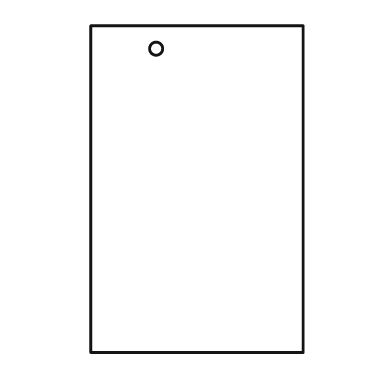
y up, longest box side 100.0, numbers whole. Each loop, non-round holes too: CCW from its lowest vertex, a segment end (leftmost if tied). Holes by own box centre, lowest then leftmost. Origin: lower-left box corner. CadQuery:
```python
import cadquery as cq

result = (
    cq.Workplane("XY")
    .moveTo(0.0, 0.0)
    .lineTo(65.0, 0.0)
    .lineTo(65.0, 100.0)
    .lineTo(0.0, 100.0)
    .close()
    .moveTo(20.0, 93.0)
    .circle(2.0)
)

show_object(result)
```